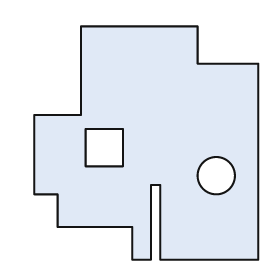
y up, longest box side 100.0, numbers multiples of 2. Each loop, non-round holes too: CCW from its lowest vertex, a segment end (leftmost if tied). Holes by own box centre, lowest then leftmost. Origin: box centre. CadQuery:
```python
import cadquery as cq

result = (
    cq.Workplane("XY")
    .moveTo(-6.0, -50.0)
    .lineTo(2.0, -50.0)
    .lineTo(2.0, -18.0)
    .lineTo(6.0, -18.0)
    .lineTo(6.0, -50.0)
    .lineTo(48.0, -50.0)
    .lineTo(48.0, 34.0)
    .lineTo(22.0, 34.0)
    .lineTo(22.0, 50.0)
    .lineTo(-28.0, 50.0)
    .lineTo(-28.0, 12.0)
    .lineTo(-48.0, 12.0)
    .lineTo(-48.0, -22.0)
    .lineTo(-38.0, -22.0)
    .lineTo(-38.0, -36.0)
    .lineTo(-6.0, -36.0)
    .close()
    .moveTo(30.0, -14.0)
    .circle(8.0)
    .moveTo(-26.0, -10.0)
    .lineTo(-10.0, -10.0)
    .lineTo(-10.0, 6.0)
    .lineTo(-26.0, 6.0)
    .close()
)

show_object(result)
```